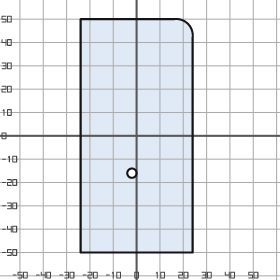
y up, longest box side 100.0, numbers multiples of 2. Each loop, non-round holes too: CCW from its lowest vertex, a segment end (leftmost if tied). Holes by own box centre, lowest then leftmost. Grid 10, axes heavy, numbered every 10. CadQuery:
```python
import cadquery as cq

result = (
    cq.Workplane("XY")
    .moveTo(-24.0, -50.0)
    .lineTo(24.0, -50.0)
    .lineTo(24.0, 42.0)
    .threePointArc((22.0, 48.0), (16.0, 50.0))
    .lineTo(-24.0, 50.0)
    .close()
    .moveTo(-2.0, -16.0)
    .circle(2.0)
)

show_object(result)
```